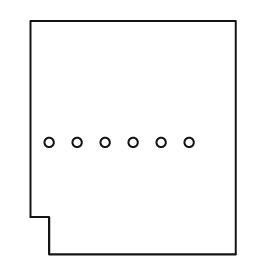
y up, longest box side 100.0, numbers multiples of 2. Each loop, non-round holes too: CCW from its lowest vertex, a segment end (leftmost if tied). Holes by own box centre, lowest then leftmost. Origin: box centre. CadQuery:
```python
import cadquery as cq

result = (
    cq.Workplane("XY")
    .moveTo(-36.0, -50.0)
    .lineTo(44.0, -50.0)
    .lineTo(44.0, 50.0)
    .lineTo(-44.0, 50.0)
    .lineTo(-44.0, -34.0)
    .lineTo(-36.0, -34.0)
    .close()
    .moveTo(-36.0, -2.0)
    .circle(2.0)
    .moveTo(-24.0, -2.0)
    .circle(2.0)
    .moveTo(-12.0, -2.0)
    .circle(2.0)
    .moveTo(0.0, -2.0)
    .circle(2.0)
    .moveTo(12.0, -2.0)
    .circle(2.0)
    .moveTo(24.0, -2.0)
    .circle(2.0)
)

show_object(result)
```